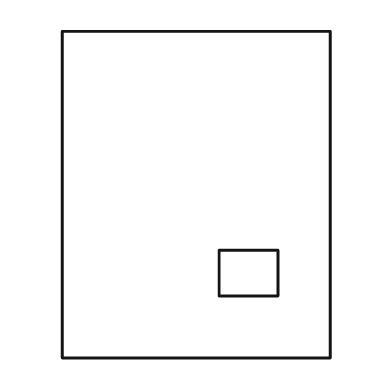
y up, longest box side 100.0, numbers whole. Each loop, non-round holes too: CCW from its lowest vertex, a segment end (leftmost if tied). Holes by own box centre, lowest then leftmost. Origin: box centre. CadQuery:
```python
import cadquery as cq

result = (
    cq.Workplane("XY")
    .moveTo(-41.0, -50.0)
    .lineTo(41.0, -50.0)
    .lineTo(41.0, 50.0)
    .lineTo(-41.0, 50.0)
    .close()
    .moveTo(7.0, -31.0)
    .lineTo(25.0, -31.0)
    .lineTo(25.0, -17.0)
    .lineTo(7.0, -17.0)
    .close()
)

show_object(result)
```